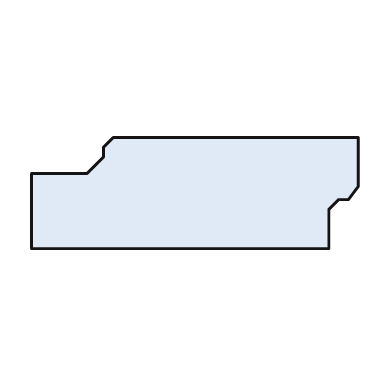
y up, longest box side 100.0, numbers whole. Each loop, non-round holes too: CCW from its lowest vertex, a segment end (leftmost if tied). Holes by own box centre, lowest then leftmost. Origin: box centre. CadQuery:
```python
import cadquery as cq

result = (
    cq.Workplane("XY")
    .moveTo(-50.0, -17.0)
    .lineTo(41.0, -17.0)
    .lineTo(41.0, -5.0)
    .lineTo(44.0, -2.0)
    .lineTo(47.0, -2.0)
    .lineTo(50.0, 2.0)
    .lineTo(50.0, 17.0)
    .lineTo(-25.0, 17.0)
    .lineTo(-28.0, 14.0)
    .lineTo(-28.0, 11.0)
    .lineTo(-33.0, 6.0)
    .lineTo(-50.0, 6.0)
    .close()
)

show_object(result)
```